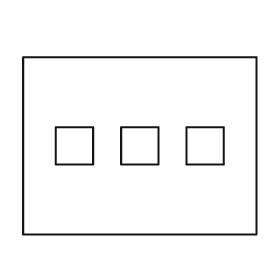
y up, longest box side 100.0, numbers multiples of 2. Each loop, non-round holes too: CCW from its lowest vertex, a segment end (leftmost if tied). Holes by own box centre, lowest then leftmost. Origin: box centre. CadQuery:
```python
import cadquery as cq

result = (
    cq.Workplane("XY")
    .moveTo(-50.0, -38.0)
    .lineTo(50.0, -38.0)
    .lineTo(50.0, 38.0)
    .lineTo(-50.0, 38.0)
    .close()
    .moveTo(-36.0, -8.0)
    .lineTo(-20.0, -8.0)
    .lineTo(-20.0, 8.0)
    .lineTo(-36.0, 8.0)
    .close()
    .moveTo(-8.0, -8.0)
    .lineTo(8.0, -8.0)
    .lineTo(8.0, 8.0)
    .lineTo(-8.0, 8.0)
    .close()
    .moveTo(20.0, -8.0)
    .lineTo(36.0, -8.0)
    .lineTo(36.0, 8.0)
    .lineTo(20.0, 8.0)
    .close()
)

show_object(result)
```